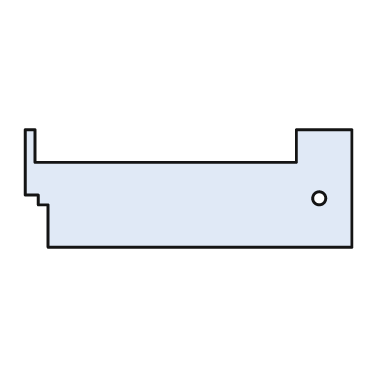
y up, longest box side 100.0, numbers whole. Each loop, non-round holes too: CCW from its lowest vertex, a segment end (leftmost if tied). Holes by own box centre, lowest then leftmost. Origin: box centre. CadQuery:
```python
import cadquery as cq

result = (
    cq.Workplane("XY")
    .moveTo(-43.0, -18.0)
    .lineTo(50.0, -18.0)
    .lineTo(50.0, 18.0)
    .lineTo(33.0, 18.0)
    .lineTo(33.0, 8.0)
    .lineTo(-47.0, 8.0)
    .lineTo(-47.0, 18.0)
    .lineTo(-50.0, 18.0)
    .lineTo(-50.0, -2.0)
    .lineTo(-46.0, -2.0)
    .lineTo(-46.0, -5.0)
    .lineTo(-43.0, -5.0)
    .close()
    .moveTo(40.0, -3.0)
    .circle(2.0)
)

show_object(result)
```